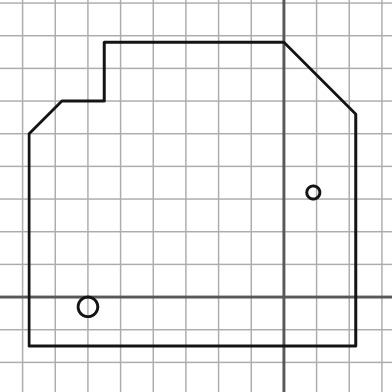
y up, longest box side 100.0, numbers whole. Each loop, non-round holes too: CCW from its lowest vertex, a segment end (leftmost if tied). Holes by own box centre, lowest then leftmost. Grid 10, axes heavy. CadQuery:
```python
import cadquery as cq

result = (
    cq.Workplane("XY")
    .moveTo(-78.0, -15.0)
    .lineTo(22.0, -15.0)
    .lineTo(22.0, 56.0)
    .lineTo(0.0, 78.0)
    .lineTo(-55.0, 78.0)
    .lineTo(-55.0, 60.0)
    .lineTo(-68.0, 60.0)
    .lineTo(-78.0, 50.0)
    .close()
    .moveTo(-60.0, -3.0)
    .circle(3.0)
    .moveTo(9.0, 32.0)
    .circle(2.0)
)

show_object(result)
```